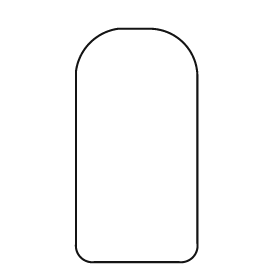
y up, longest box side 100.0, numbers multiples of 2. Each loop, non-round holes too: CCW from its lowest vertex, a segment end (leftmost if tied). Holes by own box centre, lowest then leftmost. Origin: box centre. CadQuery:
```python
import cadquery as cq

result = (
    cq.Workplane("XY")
    .moveTo(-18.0, -50.0)
    .lineTo(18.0, -50.0)
    .threePointArc((24.0, -48.0), (26.0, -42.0))
    .lineTo(26.0, 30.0)
    .threePointArc((20.0, 44.0), (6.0, 50.0))
    .lineTo(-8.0, 50.0)
    .threePointArc((-20.0, 44.0), (-26.0, 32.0))
    .lineTo(-26.0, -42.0)
    .threePointArc((-24.0, -48.0), (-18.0, -50.0))
    .close()
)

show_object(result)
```